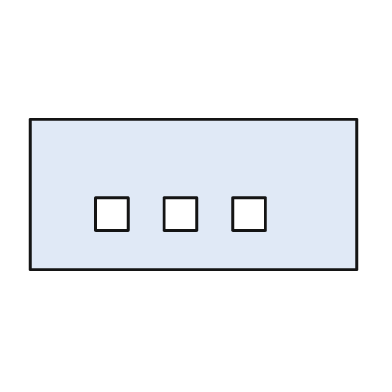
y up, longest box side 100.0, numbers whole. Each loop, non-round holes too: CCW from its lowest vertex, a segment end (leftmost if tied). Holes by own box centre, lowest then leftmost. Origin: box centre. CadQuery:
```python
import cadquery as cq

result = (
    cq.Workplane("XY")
    .moveTo(-50.0, -23.0)
    .lineTo(50.0, -23.0)
    .lineTo(50.0, 23.0)
    .lineTo(-50.0, 23.0)
    .close()
    .moveTo(-30.0, -11.0)
    .lineTo(-20.0, -11.0)
    .lineTo(-20.0, -1.0)
    .lineTo(-30.0, -1.0)
    .close()
    .moveTo(-9.0, -11.0)
    .lineTo(1.0, -11.0)
    .lineTo(1.0, -1.0)
    .lineTo(-9.0, -1.0)
    .close()
    .moveTo(12.0, -11.0)
    .lineTo(22.0, -11.0)
    .lineTo(22.0, -1.0)
    .lineTo(12.0, -1.0)
    .close()
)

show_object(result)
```